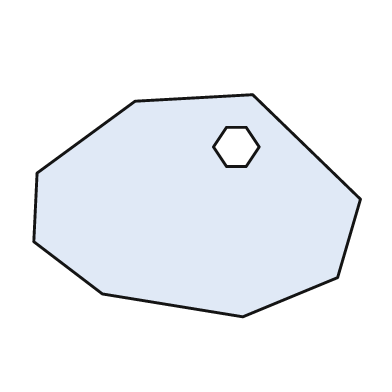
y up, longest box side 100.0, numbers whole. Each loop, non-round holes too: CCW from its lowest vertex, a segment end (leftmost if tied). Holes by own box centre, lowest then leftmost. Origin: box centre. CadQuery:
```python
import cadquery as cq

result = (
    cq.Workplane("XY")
    .moveTo(14.0, -34.0)
    .lineTo(43.0, -22.0)
    .lineTo(50.0, 2.0)
    .lineTo(17.0, 34.0)
    .lineTo(-19.0, 32.0)
    .lineTo(-49.0, 10.0)
    .lineTo(-50.0, -11.0)
    .lineTo(-29.0, -27.0)
    .close()
    .moveTo(9.0, 12.0)
    .lineTo(15.0, 12.0)
    .lineTo(19.0, 18.0)
    .lineTo(15.0, 24.0)
    .lineTo(9.0, 24.0)
    .lineTo(5.0, 18.0)
    .close()
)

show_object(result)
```